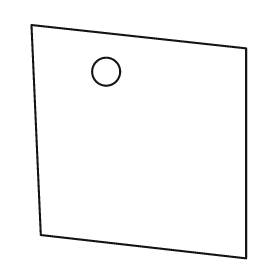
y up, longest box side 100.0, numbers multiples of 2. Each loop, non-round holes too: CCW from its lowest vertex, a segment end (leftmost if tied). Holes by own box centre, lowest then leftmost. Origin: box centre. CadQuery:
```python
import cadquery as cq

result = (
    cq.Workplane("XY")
    .moveTo(46.0, -50.0)
    .lineTo(46.0, 40.0)
    .lineTo(-46.0, 50.0)
    .lineTo(-42.0, -40.0)
    .close()
    .moveTo(-14.0, 30.0)
    .circle(6.0)
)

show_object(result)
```